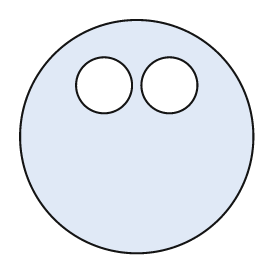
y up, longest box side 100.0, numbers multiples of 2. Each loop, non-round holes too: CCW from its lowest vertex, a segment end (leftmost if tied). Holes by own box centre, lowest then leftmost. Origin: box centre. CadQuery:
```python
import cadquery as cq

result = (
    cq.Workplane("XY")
    .moveTo(0.0, 0.0)
    .circle(50.0)
    .moveTo(-14.0, 22.0)
    .circle(12.0)
    .moveTo(14.0, 22.0)
    .circle(12.0)
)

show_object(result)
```